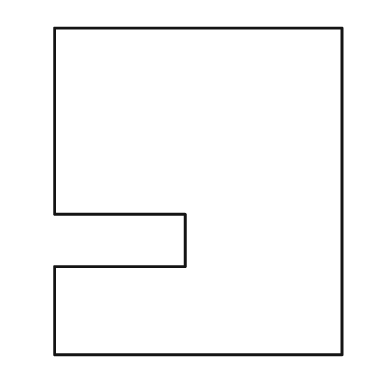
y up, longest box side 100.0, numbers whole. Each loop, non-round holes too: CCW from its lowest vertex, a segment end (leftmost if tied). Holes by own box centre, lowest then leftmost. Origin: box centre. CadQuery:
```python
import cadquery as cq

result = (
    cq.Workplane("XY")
    .moveTo(-44.0, -50.0)
    .lineTo(44.0, -50.0)
    .lineTo(44.0, 50.0)
    .lineTo(-44.0, 50.0)
    .lineTo(-44.0, -7.0)
    .lineTo(-4.0, -7.0)
    .lineTo(-4.0, -23.0)
    .lineTo(-44.0, -23.0)
    .close()
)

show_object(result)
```